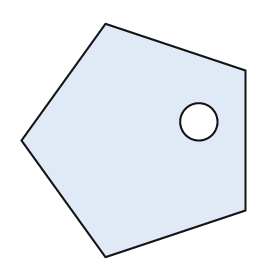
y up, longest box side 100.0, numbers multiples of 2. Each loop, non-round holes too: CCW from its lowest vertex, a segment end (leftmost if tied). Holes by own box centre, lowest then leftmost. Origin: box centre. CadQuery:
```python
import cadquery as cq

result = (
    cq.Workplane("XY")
    .moveTo(-12.0, -50.0)
    .lineTo(48.0, -30.0)
    .lineTo(48.0, 30.0)
    .lineTo(-12.0, 50.0)
    .lineTo(-48.0, 0.0)
    .close()
    .moveTo(28.0, 8.0)
    .circle(8.0)
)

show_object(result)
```